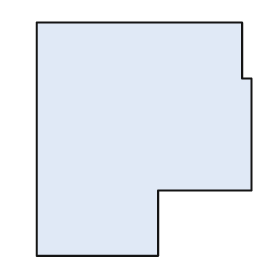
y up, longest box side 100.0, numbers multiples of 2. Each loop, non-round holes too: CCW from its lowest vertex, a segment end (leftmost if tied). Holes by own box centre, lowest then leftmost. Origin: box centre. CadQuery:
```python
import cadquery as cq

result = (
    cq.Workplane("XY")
    .moveTo(-46.0, -50.0)
    .lineTo(6.0, -50.0)
    .lineTo(6.0, -22.0)
    .lineTo(46.0, -22.0)
    .lineTo(46.0, 26.0)
    .lineTo(42.0, 26.0)
    .lineTo(42.0, 50.0)
    .lineTo(-46.0, 50.0)
    .close()
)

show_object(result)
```